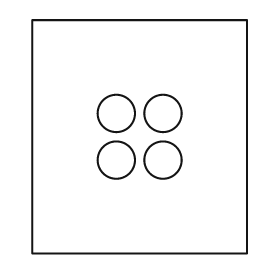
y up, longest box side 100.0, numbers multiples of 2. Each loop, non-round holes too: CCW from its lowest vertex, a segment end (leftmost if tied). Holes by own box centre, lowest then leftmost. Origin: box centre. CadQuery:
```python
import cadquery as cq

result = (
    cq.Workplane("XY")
    .moveTo(-46.0, -50.0)
    .lineTo(46.0, -50.0)
    .lineTo(46.0, 50.0)
    .lineTo(-46.0, 50.0)
    .close()
    .moveTo(-10.0, -10.0)
    .circle(8.0)
    .moveTo(10.0, -10.0)
    .circle(8.0)
    .moveTo(-10.0, 10.0)
    .circle(8.0)
    .moveTo(10.0, 10.0)
    .circle(8.0)
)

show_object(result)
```